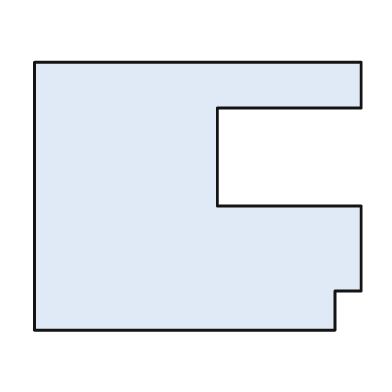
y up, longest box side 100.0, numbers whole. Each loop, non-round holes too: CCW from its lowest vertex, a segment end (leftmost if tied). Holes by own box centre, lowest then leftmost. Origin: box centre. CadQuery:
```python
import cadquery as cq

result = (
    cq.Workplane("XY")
    .moveTo(-50.0, -41.0)
    .lineTo(42.0, -41.0)
    .lineTo(42.0, -29.0)
    .lineTo(50.0, -29.0)
    .lineTo(50.0, -3.0)
    .lineTo(6.0, -3.0)
    .lineTo(6.0, 27.0)
    .lineTo(50.0, 27.0)
    .lineTo(50.0, 41.0)
    .lineTo(-50.0, 41.0)
    .close()
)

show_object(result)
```